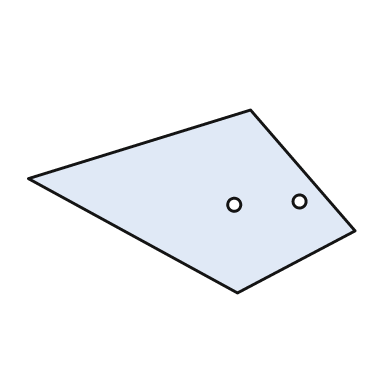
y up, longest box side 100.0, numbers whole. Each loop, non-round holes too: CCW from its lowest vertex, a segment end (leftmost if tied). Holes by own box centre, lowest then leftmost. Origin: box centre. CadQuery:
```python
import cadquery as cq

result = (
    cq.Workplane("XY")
    .moveTo(14.0, -28.0)
    .lineTo(50.0, -9.0)
    .lineTo(18.0, 28.0)
    .lineTo(-50.0, 7.0)
    .close()
    .moveTo(13.0, -1.0)
    .circle(2.0)
    .moveTo(33.0, 0.0)
    .circle(2.0)
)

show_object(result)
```